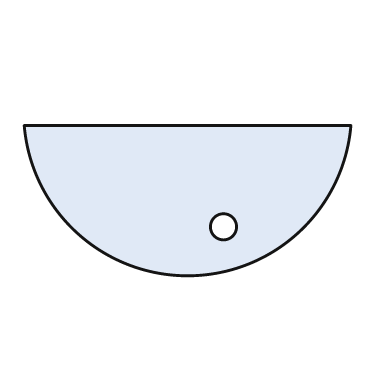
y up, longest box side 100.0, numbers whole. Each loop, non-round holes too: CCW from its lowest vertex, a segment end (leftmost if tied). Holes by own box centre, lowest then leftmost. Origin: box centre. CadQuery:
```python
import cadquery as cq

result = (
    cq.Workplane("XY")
    .moveTo(-50.0, 23.0)
    .threePointArc((0.0, -23.0), (50.0, 23.0))
    .close()
    .moveTo(11.0, -8.0)
    .circle(4.0)
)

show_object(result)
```